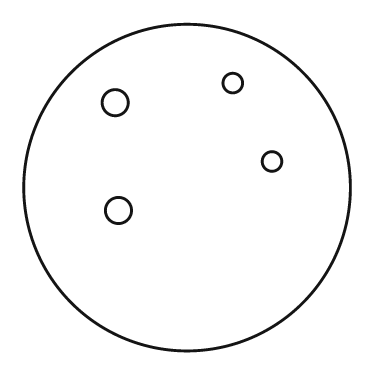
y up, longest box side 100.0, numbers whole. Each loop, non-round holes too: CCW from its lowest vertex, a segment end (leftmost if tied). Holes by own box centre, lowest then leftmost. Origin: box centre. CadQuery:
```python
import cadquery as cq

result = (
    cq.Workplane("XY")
    .moveTo(0.0, 0.0)
    .circle(50.0)
    .moveTo(-21.0, -7.0)
    .circle(4.0)
    .moveTo(26.0, 8.0)
    .circle(3.0)
    .moveTo(-22.0, 26.0)
    .circle(4.0)
    .moveTo(14.0, 32.0)
    .circle(3.0)
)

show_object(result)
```